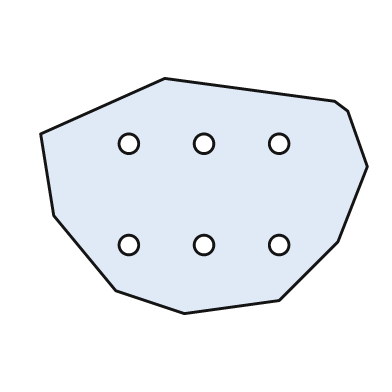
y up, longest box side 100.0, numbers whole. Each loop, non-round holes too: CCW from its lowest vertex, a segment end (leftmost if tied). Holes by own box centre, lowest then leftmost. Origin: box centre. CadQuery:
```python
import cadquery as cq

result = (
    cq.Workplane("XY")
    .moveTo(-6.0, -36.0)
    .lineTo(23.0, -32.0)
    .lineTo(41.0, -14.0)
    .lineTo(50.0, 9.0)
    .lineTo(44.0, 26.0)
    .lineTo(40.0, 29.0)
    .lineTo(-12.0, 36.0)
    .lineTo(-50.0, 19.0)
    .lineTo(-46.0, -6.0)
    .lineTo(-27.0, -29.0)
    .close()
    .moveTo(-23.0, -15.0)
    .circle(3.0)
    .moveTo(0.0, -15.0)
    .circle(3.0)
    .moveTo(23.0, -15.0)
    .circle(3.0)
    .moveTo(-23.0, 16.0)
    .circle(3.0)
    .moveTo(0.0, 16.0)
    .circle(3.0)
    .moveTo(23.0, 16.0)
    .circle(3.0)
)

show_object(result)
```